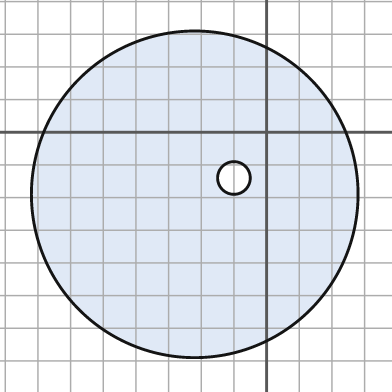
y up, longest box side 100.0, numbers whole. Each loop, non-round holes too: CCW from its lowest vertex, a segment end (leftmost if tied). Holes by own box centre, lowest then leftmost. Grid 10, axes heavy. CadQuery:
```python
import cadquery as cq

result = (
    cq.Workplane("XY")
    .moveTo(-22.0, -19.0)
    .circle(50.0)
    .moveTo(-10.0, -14.0)
    .circle(5.0)
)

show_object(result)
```